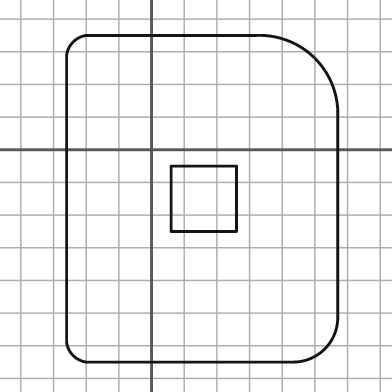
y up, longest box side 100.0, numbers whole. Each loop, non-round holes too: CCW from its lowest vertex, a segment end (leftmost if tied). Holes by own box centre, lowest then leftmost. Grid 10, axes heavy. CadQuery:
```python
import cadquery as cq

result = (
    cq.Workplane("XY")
    .moveTo(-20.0, -65.0)
    .lineTo(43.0, -65.0)
    .threePointArc((53.0, -61.0), (57.0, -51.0))
    .lineTo(57.0, 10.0)
    .threePointArc((50.0, 28.0), (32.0, 35.0))
    .lineTo(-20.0, 35.0)
    .threePointArc((-24.0, 33.0), (-26.0, 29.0))
    .lineTo(-26.0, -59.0)
    .threePointArc((-24.0, -63.0), (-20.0, -65.0))
    .close()
    .moveTo(6.0, -25.0)
    .lineTo(26.0, -25.0)
    .lineTo(26.0, -5.0)
    .lineTo(6.0, -5.0)
    .close()
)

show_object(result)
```